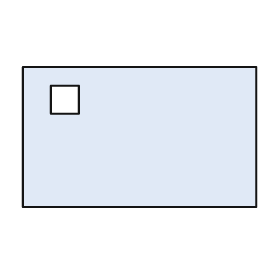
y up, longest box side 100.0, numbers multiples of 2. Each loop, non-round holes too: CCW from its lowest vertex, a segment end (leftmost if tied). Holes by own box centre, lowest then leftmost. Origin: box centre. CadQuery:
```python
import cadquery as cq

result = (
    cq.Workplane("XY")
    .moveTo(-50.0, -30.0)
    .lineTo(50.0, -30.0)
    .lineTo(50.0, 30.0)
    .lineTo(-50.0, 30.0)
    .close()
    .moveTo(-38.0, 10.0)
    .lineTo(-26.0, 10.0)
    .lineTo(-26.0, 22.0)
    .lineTo(-38.0, 22.0)
    .close()
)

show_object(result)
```